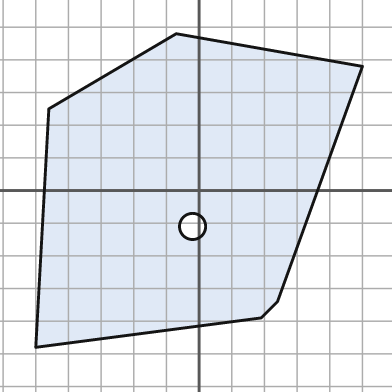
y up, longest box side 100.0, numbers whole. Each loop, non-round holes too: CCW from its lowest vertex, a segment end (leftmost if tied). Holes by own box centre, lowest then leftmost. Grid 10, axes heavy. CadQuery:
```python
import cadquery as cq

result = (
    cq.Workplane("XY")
    .moveTo(-50.0, -48.0)
    .lineTo(19.0, -39.0)
    .lineTo(24.0, -34.0)
    .lineTo(50.0, 38.0)
    .lineTo(-7.0, 48.0)
    .lineTo(-46.0, 25.0)
    .close()
    .moveTo(-2.0, -11.0)
    .circle(4.0)
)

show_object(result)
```